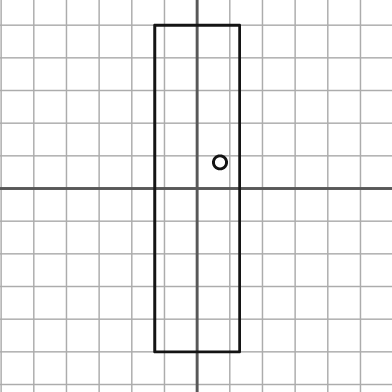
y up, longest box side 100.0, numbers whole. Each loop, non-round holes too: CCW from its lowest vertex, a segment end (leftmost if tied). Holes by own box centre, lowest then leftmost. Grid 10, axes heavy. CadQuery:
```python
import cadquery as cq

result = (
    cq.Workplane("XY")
    .moveTo(-13.0, -50.0)
    .lineTo(13.0, -50.0)
    .lineTo(13.0, 50.0)
    .lineTo(-13.0, 50.0)
    .close()
    .moveTo(7.0, 8.0)
    .circle(2.0)
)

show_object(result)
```